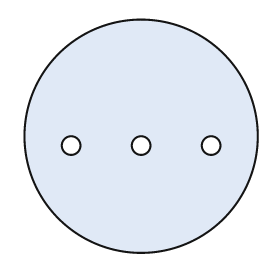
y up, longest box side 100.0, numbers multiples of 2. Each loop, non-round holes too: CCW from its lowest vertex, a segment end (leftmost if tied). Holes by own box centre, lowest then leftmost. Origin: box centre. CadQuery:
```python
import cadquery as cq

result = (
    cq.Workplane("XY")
    .moveTo(0.0, 0.0)
    .circle(50.0)
    .moveTo(-30.0, -4.0)
    .circle(4.0)
    .moveTo(0.0, -4.0)
    .circle(4.0)
    .moveTo(30.0, -4.0)
    .circle(4.0)
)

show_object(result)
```